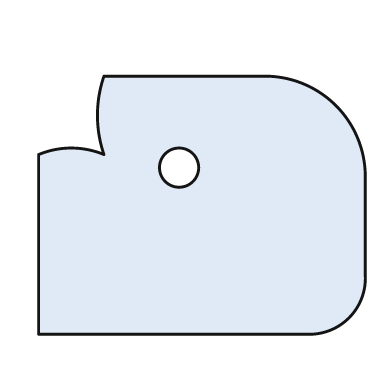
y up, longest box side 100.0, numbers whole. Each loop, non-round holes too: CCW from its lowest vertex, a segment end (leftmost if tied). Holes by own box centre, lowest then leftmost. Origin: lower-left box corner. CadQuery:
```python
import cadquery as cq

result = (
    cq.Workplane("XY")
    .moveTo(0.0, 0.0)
    .lineTo(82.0, 0.0)
    .threePointArc((95.0, 5.0), (100.0, 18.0))
    .lineTo(100.0, 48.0)
    .threePointArc((91.0, 70.0), (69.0, 79.0))
    .lineTo(20.0, 79.0)
    .threePointArc((18.0, 67.0), (20.0, 55.0))
    .threePointArc((10.0, 57.0), (0.0, 55.0))
    .close()
    .moveTo(43.0, 51.0)
    .circle(6.0)
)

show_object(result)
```